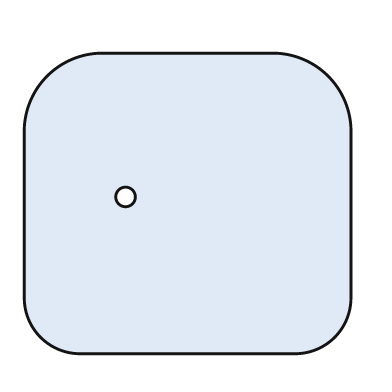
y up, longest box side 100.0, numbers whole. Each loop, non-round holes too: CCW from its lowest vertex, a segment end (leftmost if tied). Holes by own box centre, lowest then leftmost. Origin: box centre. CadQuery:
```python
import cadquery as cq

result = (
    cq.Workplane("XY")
    .moveTo(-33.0, -46.0)
    .lineTo(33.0, -46.0)
    .threePointArc((45.0, -41.0), (50.0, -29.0))
    .lineTo(50.0, 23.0)
    .threePointArc((43.0, 39.0), (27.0, 46.0))
    .lineTo(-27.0, 46.0)
    .threePointArc((-43.0, 39.0), (-50.0, 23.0))
    .lineTo(-50.0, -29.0)
    .threePointArc((-45.0, -41.0), (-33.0, -46.0))
    .close()
    .moveTo(-19.0, 2.0)
    .circle(3.0)
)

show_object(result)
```